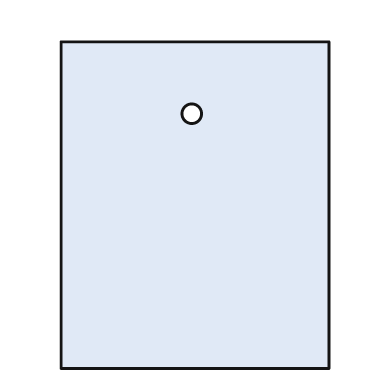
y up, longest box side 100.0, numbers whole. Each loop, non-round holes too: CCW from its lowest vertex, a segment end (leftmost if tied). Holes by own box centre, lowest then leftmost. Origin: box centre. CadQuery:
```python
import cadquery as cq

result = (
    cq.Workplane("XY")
    .moveTo(-41.0, -50.0)
    .lineTo(41.0, -50.0)
    .lineTo(41.0, 50.0)
    .lineTo(-41.0, 50.0)
    .close()
    .moveTo(-1.0, 28.0)
    .circle(3.0)
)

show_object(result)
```